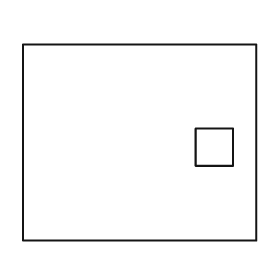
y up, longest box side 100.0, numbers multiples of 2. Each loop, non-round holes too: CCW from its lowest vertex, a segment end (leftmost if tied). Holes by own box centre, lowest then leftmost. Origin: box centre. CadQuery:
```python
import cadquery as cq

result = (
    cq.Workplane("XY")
    .moveTo(-50.0, -42.0)
    .lineTo(50.0, -42.0)
    .lineTo(50.0, 42.0)
    .lineTo(-50.0, 42.0)
    .close()
    .moveTo(24.0, -10.0)
    .lineTo(40.0, -10.0)
    .lineTo(40.0, 6.0)
    .lineTo(24.0, 6.0)
    .close()
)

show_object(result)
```